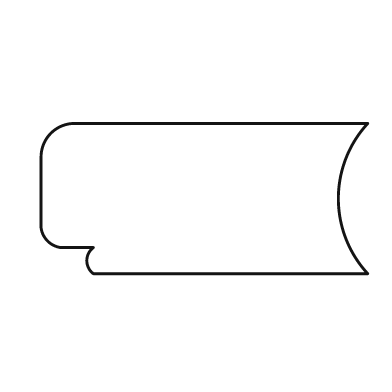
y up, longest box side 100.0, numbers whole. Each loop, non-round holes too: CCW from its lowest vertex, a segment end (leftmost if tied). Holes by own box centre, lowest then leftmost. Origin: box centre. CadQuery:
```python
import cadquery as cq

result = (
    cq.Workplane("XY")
    .moveTo(-34.0, -23.0)
    .lineTo(50.0, -23.0)
    .threePointArc((41.0, 0.0), (50.0, 23.0))
    .lineTo(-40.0, 23.0)
    .threePointArc((-47.0, 20.0), (-50.0, 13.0))
    .lineTo(-50.0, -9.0)
    .threePointArc((-48.0, -13.0), (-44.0, -15.0))
    .lineTo(-34.0, -15.0)
    .threePointArc((-36.0, -19.0), (-34.0, -23.0))
    .close()
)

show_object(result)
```